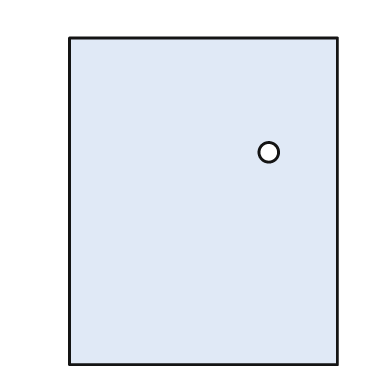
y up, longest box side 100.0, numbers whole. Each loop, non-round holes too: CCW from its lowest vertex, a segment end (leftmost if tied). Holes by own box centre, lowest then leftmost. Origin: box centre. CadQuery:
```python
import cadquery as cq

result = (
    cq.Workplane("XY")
    .moveTo(-41.0, -50.0)
    .lineTo(41.0, -50.0)
    .lineTo(41.0, 50.0)
    .lineTo(-41.0, 50.0)
    .close()
    .moveTo(20.0, 15.0)
    .circle(3.0)
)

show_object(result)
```